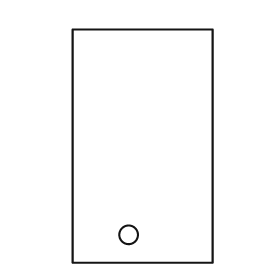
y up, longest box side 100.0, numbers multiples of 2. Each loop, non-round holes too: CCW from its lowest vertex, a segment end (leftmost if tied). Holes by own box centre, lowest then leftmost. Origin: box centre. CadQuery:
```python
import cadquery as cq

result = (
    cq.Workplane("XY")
    .moveTo(-30.0, -50.0)
    .lineTo(30.0, -50.0)
    .lineTo(30.0, 50.0)
    .lineTo(-30.0, 50.0)
    .close()
    .moveTo(-6.0, -38.0)
    .circle(4.0)
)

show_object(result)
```